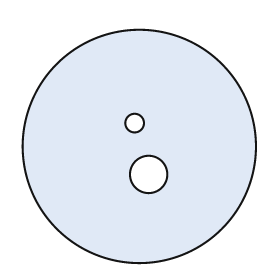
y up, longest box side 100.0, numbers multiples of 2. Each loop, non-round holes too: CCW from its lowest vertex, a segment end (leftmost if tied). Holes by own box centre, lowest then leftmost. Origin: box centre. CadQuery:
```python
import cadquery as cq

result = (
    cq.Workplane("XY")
    .moveTo(0.0, 0.0)
    .circle(50.0)
    .moveTo(4.0, -12.0)
    .circle(8.0)
    .moveTo(-2.0, 10.0)
    .circle(4.0)
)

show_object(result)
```